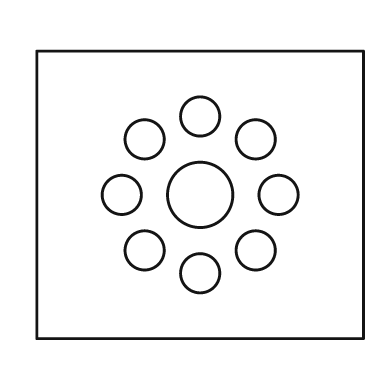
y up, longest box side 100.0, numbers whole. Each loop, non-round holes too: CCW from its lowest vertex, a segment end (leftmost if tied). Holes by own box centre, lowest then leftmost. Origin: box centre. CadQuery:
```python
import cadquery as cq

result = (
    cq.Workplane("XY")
    .moveTo(-50.0, -44.0)
    .lineTo(50.0, -44.0)
    .lineTo(50.0, 44.0)
    .lineTo(-50.0, 44.0)
    .close()
    .moveTo(0.0, -24.0)
    .circle(6.0)
    .moveTo(-17.0, -17.0)
    .circle(6.0)
    .moveTo(17.0, -17.0)
    .circle(6.0)
    .moveTo(-24.0, 0.0)
    .circle(6.0)
    .moveTo(0.0, 0.0)
    .circle(10.0)
    .moveTo(24.0, 0.0)
    .circle(6.0)
    .moveTo(-17.0, 17.0)
    .circle(6.0)
    .moveTo(17.0, 17.0)
    .circle(6.0)
    .moveTo(0.0, 24.0)
    .circle(6.0)
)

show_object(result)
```